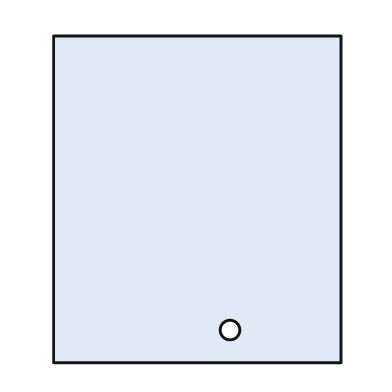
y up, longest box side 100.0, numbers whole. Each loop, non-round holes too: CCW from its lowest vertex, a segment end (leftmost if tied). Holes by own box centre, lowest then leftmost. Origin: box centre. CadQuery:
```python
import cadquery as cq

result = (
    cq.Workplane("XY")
    .moveTo(-44.0, -50.0)
    .lineTo(44.0, -50.0)
    .lineTo(44.0, 50.0)
    .lineTo(-44.0, 50.0)
    .close()
    .moveTo(10.0, -40.0)
    .circle(3.0)
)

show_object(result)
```